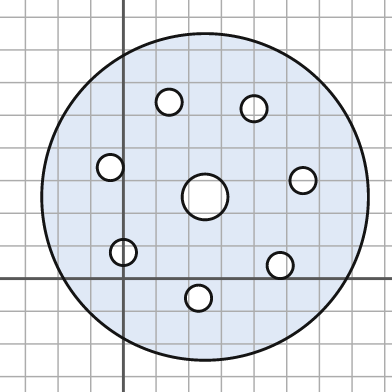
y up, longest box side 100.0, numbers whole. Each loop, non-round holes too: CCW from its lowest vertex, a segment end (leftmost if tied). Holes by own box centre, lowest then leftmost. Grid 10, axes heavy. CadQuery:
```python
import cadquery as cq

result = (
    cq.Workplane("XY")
    .moveTo(25.0, 25.0)
    .circle(50.0)
    .moveTo(23.0, -6.0)
    .circle(4.0)
    .moveTo(48.0, 4.0)
    .circle(4.0)
    .moveTo(0.0, 8.0)
    .circle(4.0)
    .moveTo(25.0, 25.0)
    .circle(7.0)
    .moveTo(55.0, 30.0)
    .circle(4.0)
    .moveTo(-4.0, 34.0)
    .circle(4.0)
    .moveTo(40.0, 52.0)
    .circle(4.0)
    .moveTo(14.0, 54.0)
    .circle(4.0)
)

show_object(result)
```